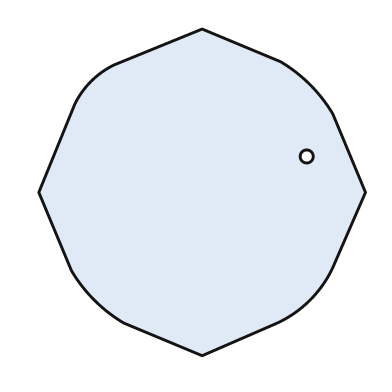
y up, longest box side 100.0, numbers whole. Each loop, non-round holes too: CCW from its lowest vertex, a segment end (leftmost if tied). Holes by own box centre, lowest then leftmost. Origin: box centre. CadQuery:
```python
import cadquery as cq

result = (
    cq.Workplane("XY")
    .moveTo(0.0, -50.0)
    .lineTo(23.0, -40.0)
    .threePointArc((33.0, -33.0), (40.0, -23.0))
    .lineTo(50.0, 0.0)
    .lineTo(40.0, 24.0)
    .threePointArc((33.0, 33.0), (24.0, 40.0))
    .lineTo(0.0, 50.0)
    .lineTo(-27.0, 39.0)
    .threePointArc((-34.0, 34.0), (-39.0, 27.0))
    .lineTo(-50.0, 0.0)
    .lineTo(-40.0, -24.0)
    .threePointArc((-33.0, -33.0), (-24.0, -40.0))
    .close()
    .moveTo(32.0, 11.0)
    .circle(2.0)
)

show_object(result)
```